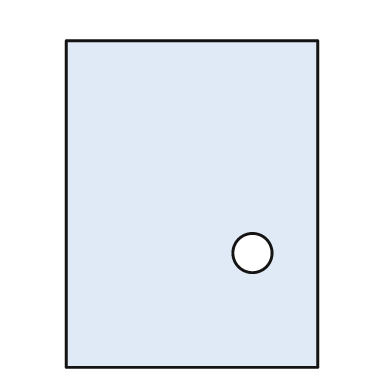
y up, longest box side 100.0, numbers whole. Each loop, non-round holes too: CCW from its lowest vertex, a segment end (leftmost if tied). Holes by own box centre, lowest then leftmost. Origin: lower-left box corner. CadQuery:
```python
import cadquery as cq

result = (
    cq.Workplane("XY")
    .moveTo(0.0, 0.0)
    .lineTo(77.0, 0.0)
    .lineTo(77.0, 100.0)
    .lineTo(0.0, 100.0)
    .close()
    .moveTo(57.0, 35.0)
    .circle(6.0)
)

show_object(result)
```